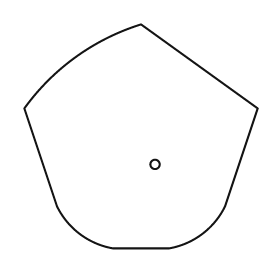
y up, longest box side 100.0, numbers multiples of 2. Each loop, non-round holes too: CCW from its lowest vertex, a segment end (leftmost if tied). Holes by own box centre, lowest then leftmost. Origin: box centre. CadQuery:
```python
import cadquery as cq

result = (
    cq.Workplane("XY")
    .moveTo(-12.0, -48.0)
    .lineTo(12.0, -48.0)
    .threePointArc((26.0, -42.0), (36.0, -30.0))
    .lineTo(50.0, 12.0)
    .lineTo(0.0, 48.0)
    .threePointArc((-28.0, 34.0), (-50.0, 12.0))
    .lineTo(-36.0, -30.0)
    .threePointArc((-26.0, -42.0), (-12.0, -48.0))
    .close()
    .moveTo(6.0, -12.0)
    .circle(2.0)
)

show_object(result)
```